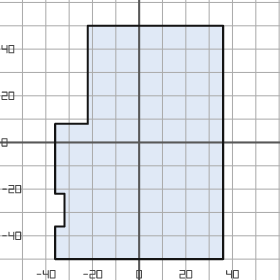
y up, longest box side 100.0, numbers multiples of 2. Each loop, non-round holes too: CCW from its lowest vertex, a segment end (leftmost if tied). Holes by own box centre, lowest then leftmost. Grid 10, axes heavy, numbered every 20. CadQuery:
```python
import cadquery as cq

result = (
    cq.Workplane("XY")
    .moveTo(-36.0, -50.0)
    .lineTo(36.0, -50.0)
    .lineTo(36.0, 50.0)
    .lineTo(-22.0, 50.0)
    .lineTo(-22.0, 8.0)
    .lineTo(-36.0, 8.0)
    .lineTo(-36.0, -22.0)
    .lineTo(-32.0, -22.0)
    .lineTo(-32.0, -36.0)
    .lineTo(-36.0, -36.0)
    .close()
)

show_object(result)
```